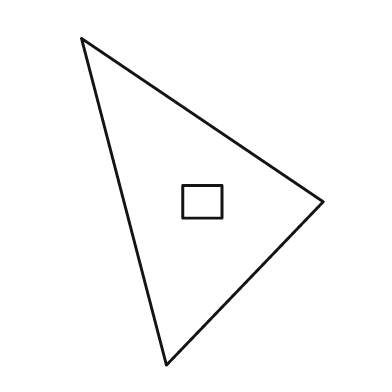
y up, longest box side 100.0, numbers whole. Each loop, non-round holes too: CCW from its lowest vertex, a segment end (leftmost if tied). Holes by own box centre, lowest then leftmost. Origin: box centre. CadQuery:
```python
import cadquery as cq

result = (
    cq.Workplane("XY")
    .moveTo(-11.0, -50.0)
    .lineTo(37.0, 0.0)
    .lineTo(-37.0, 50.0)
    .close()
    .moveTo(-6.0, -5.0)
    .lineTo(6.0, -5.0)
    .lineTo(6.0, 5.0)
    .lineTo(-6.0, 5.0)
    .close()
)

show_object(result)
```